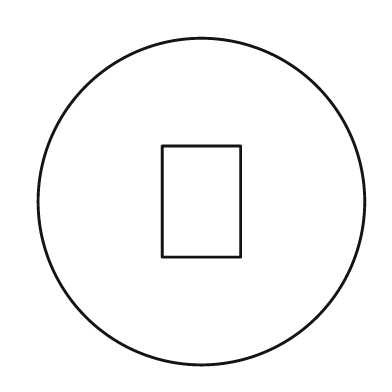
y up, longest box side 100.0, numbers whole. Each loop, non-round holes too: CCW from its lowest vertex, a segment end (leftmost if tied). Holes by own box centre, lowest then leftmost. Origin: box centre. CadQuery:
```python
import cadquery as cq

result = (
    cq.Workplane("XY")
    .moveTo(0.0, 0.0)
    .circle(50.0)
    .moveTo(-12.0, -17.0)
    .lineTo(12.0, -17.0)
    .lineTo(12.0, 17.0)
    .lineTo(-12.0, 17.0)
    .close()
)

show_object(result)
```